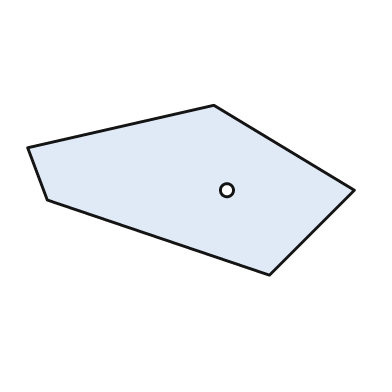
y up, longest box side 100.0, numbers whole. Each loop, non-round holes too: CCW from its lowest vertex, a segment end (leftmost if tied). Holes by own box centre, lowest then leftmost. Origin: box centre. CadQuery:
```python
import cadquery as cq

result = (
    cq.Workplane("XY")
    .moveTo(24.0, -26.0)
    .lineTo(50.0, 0.0)
    .lineTo(7.0, 26.0)
    .lineTo(-50.0, 13.0)
    .lineTo(-44.0, -3.0)
    .close()
    .moveTo(11.0, 0.0)
    .circle(2.0)
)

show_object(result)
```